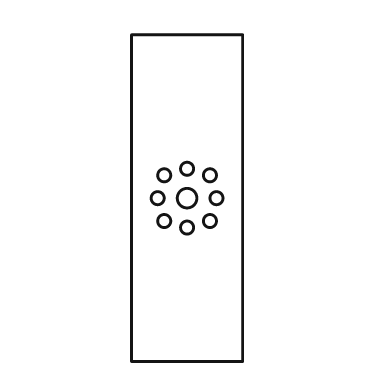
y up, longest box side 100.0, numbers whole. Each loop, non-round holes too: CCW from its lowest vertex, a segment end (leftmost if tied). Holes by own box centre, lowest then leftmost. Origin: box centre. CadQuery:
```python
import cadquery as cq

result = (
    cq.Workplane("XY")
    .moveTo(-17.0, -50.0)
    .lineTo(17.0, -50.0)
    .lineTo(17.0, 50.0)
    .lineTo(-17.0, 50.0)
    .close()
    .moveTo(0.0, -9.0)
    .circle(2.0)
    .moveTo(-7.0, -7.0)
    .circle(2.0)
    .moveTo(7.0, -7.0)
    .circle(2.0)
    .moveTo(-9.0, 0.0)
    .circle(2.0)
    .moveTo(0.0, 0.0)
    .circle(3.0)
    .moveTo(9.0, 0.0)
    .circle(2.0)
    .moveTo(-7.0, 7.0)
    .circle(2.0)
    .moveTo(7.0, 7.0)
    .circle(2.0)
    .moveTo(0.0, 9.0)
    .circle(2.0)
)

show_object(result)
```